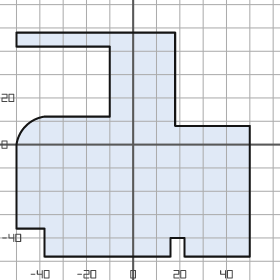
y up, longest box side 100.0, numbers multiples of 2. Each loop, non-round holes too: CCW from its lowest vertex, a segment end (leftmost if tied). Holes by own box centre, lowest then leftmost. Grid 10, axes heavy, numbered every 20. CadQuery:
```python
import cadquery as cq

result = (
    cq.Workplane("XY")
    .moveTo(-38.0, -48.0)
    .lineTo(16.0, -48.0)
    .lineTo(16.0, -40.0)
    .lineTo(22.0, -40.0)
    .lineTo(22.0, -48.0)
    .lineTo(50.0, -48.0)
    .lineTo(50.0, 8.0)
    .lineTo(18.0, 8.0)
    .lineTo(18.0, 48.0)
    .lineTo(-50.0, 48.0)
    .lineTo(-50.0, 42.0)
    .lineTo(-10.0, 42.0)
    .lineTo(-10.0, 12.0)
    .lineTo(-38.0, 12.0)
    .threePointArc((-46.0, 8.0), (-50.0, 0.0))
    .lineTo(-50.0, -36.0)
    .lineTo(-38.0, -36.0)
    .close()
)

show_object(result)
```